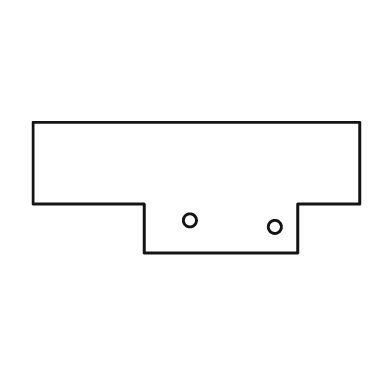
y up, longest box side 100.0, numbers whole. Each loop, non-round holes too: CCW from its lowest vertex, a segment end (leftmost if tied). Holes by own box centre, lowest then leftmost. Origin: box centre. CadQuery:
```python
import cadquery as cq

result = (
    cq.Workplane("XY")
    .moveTo(-16.0, -20.0)
    .lineTo(31.0, -20.0)
    .lineTo(31.0, -5.0)
    .lineTo(50.0, -5.0)
    .lineTo(50.0, 20.0)
    .lineTo(-50.0, 20.0)
    .lineTo(-50.0, -5.0)
    .lineTo(-16.0, -5.0)
    .close()
    .moveTo(24.0, -12.0)
    .circle(2.0)
    .moveTo(-2.0, -10.0)
    .circle(2.0)
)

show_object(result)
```